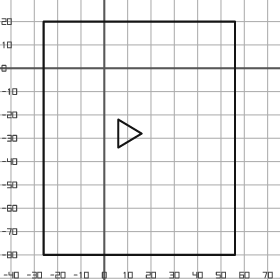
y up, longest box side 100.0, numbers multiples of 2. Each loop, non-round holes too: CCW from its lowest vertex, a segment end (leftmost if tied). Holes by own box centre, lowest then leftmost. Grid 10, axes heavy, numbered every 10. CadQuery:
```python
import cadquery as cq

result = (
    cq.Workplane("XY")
    .moveTo(-26.0, -80.0)
    .lineTo(56.0, -80.0)
    .lineTo(56.0, 20.0)
    .lineTo(-26.0, 20.0)
    .close()
    .moveTo(6.0, -34.0)
    .lineTo(16.0, -28.0)
    .lineTo(6.0, -22.0)
    .close()
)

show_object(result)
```